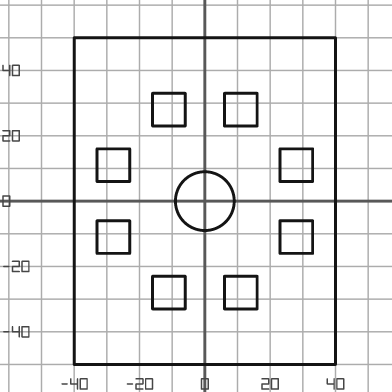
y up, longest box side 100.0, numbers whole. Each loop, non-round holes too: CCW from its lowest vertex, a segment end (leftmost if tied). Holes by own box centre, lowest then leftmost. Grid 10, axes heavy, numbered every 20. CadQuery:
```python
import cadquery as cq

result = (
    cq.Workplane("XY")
    .moveTo(-40.0, -50.0)
    .lineTo(40.0, -50.0)
    .lineTo(40.0, 50.0)
    .lineTo(-40.0, 50.0)
    .close()
    .moveTo(-16.0, -33.0)
    .lineTo(-6.0, -33.0)
    .lineTo(-6.0, -23.0)
    .lineTo(-16.0, -23.0)
    .close()
    .moveTo(6.0, -33.0)
    .lineTo(16.0, -33.0)
    .lineTo(16.0, -23.0)
    .lineTo(6.0, -23.0)
    .close()
    .moveTo(-33.0, -16.0)
    .lineTo(-23.0, -16.0)
    .lineTo(-23.0, -6.0)
    .lineTo(-33.0, -6.0)
    .close()
    .moveTo(23.0, -16.0)
    .lineTo(33.0, -16.0)
    .lineTo(33.0, -6.0)
    .lineTo(23.0, -6.0)
    .close()
    .moveTo(0.0, 0.0)
    .circle(9.0)
    .moveTo(-33.0, 6.0)
    .lineTo(-23.0, 6.0)
    .lineTo(-23.0, 16.0)
    .lineTo(-33.0, 16.0)
    .close()
    .moveTo(23.0, 6.0)
    .lineTo(33.0, 6.0)
    .lineTo(33.0, 16.0)
    .lineTo(23.0, 16.0)
    .close()
    .moveTo(-16.0, 23.0)
    .lineTo(-6.0, 23.0)
    .lineTo(-6.0, 33.0)
    .lineTo(-16.0, 33.0)
    .close()
    .moveTo(6.0, 23.0)
    .lineTo(16.0, 23.0)
    .lineTo(16.0, 33.0)
    .lineTo(6.0, 33.0)
    .close()
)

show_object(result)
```